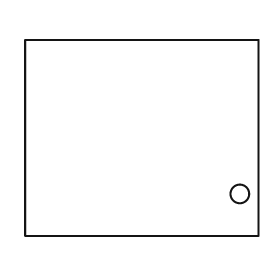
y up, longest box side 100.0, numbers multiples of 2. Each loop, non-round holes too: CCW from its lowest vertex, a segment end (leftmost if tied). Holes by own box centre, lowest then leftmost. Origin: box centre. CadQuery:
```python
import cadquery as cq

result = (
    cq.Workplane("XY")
    .moveTo(-50.0, -42.0)
    .lineTo(50.0, -42.0)
    .lineTo(50.0, 42.0)
    .lineTo(-50.0, 42.0)
    .close()
    .moveTo(42.0, -24.0)
    .circle(4.0)
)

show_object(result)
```